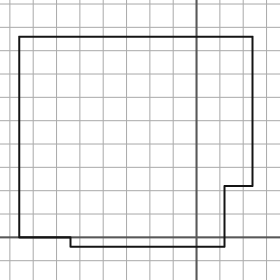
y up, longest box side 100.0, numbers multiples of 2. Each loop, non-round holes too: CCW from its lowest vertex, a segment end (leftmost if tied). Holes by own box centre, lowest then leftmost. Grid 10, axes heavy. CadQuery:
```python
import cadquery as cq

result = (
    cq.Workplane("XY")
    .moveTo(-54.0, -4.0)
    .lineTo(12.0, -4.0)
    .lineTo(12.0, 22.0)
    .lineTo(24.0, 22.0)
    .lineTo(24.0, 86.0)
    .lineTo(-76.0, 86.0)
    .lineTo(-76.0, 0.0)
    .lineTo(-54.0, 0.0)
    .close()
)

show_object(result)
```